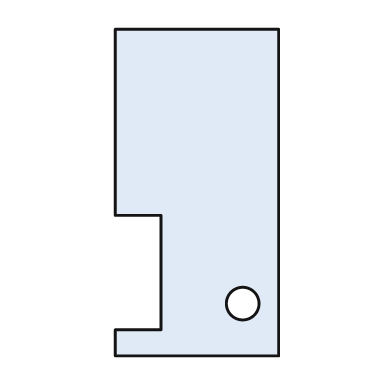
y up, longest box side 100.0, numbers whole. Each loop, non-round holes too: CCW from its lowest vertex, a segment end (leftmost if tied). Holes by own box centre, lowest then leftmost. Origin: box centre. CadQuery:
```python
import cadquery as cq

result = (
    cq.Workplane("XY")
    .moveTo(-25.0, -50.0)
    .lineTo(25.0, -50.0)
    .lineTo(25.0, 50.0)
    .lineTo(-25.0, 50.0)
    .lineTo(-25.0, -7.0)
    .lineTo(-11.0, -7.0)
    .lineTo(-11.0, -42.0)
    .lineTo(-25.0, -42.0)
    .close()
    .moveTo(14.0, -34.0)
    .circle(5.0)
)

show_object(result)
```